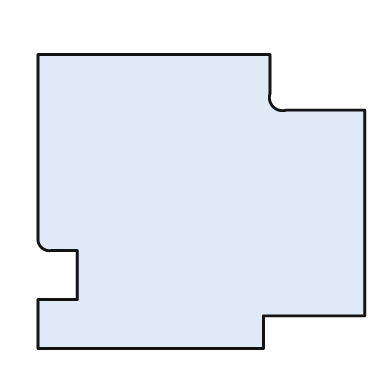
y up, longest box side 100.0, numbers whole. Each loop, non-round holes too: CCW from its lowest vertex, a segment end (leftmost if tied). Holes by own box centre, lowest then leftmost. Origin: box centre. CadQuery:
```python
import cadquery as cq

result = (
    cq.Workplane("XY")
    .moveTo(-50.0, -45.0)
    .lineTo(19.0, -45.0)
    .lineTo(19.0, -35.0)
    .lineTo(50.0, -35.0)
    .lineTo(50.0, 28.0)
    .lineTo(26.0, 28.0)
    .threePointArc((22.0, 29.0), (21.0, 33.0))
    .lineTo(21.0, 45.0)
    .lineTo(-50.0, 45.0)
    .lineTo(-50.0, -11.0)
    .threePointArc((-49.0, -14.0), (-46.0, -15.0))
    .lineTo(-38.0, -15.0)
    .lineTo(-38.0, -30.0)
    .lineTo(-50.0, -30.0)
    .close()
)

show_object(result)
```